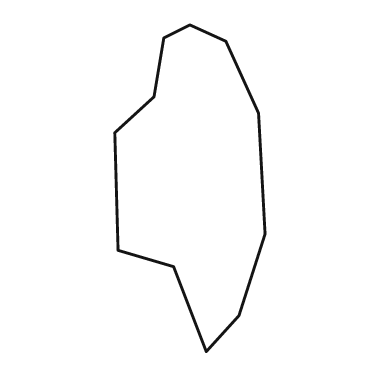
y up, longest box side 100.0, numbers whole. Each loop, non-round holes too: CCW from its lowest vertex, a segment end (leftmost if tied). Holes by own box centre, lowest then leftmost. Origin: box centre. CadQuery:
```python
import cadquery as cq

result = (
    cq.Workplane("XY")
    .moveTo(5.0, -50.0)
    .lineTo(15.0, -39.0)
    .lineTo(23.0, -14.0)
    .lineTo(21.0, 23.0)
    .lineTo(11.0, 45.0)
    .lineTo(0.0, 50.0)
    .lineTo(-8.0, 46.0)
    .lineTo(-11.0, 28.0)
    .lineTo(-23.0, 17.0)
    .lineTo(-22.0, -19.0)
    .lineTo(-5.0, -24.0)
    .close()
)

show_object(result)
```